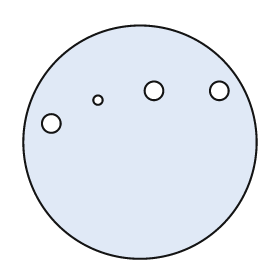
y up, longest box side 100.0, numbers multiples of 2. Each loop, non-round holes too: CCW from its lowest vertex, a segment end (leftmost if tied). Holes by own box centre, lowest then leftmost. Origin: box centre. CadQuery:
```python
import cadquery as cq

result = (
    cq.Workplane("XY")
    .moveTo(0.0, 0.0)
    .circle(50.0)
    .moveTo(-38.0, 8.0)
    .circle(4.0)
    .moveTo(-18.0, 18.0)
    .circle(2.0)
    .moveTo(6.0, 22.0)
    .circle(4.0)
    .moveTo(34.0, 22.0)
    .circle(4.0)
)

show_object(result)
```